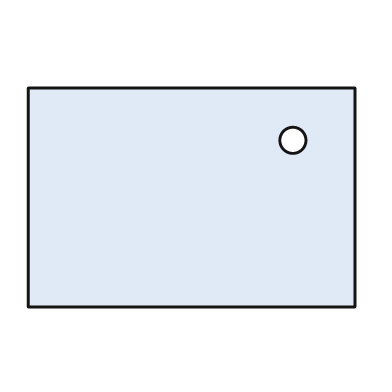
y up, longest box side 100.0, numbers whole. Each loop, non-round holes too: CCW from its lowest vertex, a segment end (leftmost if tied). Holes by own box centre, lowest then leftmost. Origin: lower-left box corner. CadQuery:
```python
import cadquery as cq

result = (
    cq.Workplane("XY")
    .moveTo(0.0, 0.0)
    .lineTo(100.0, 0.0)
    .lineTo(100.0, 67.0)
    .lineTo(0.0, 67.0)
    .close()
    .moveTo(81.0, 51.0)
    .circle(4.0)
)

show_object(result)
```